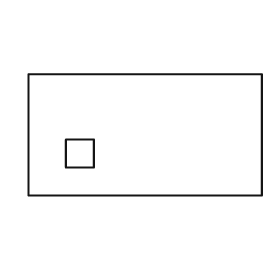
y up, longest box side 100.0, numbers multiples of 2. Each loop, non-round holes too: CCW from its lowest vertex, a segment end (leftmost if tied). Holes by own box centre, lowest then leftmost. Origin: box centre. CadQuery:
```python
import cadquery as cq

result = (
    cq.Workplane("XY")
    .moveTo(-50.0, -26.0)
    .lineTo(50.0, -26.0)
    .lineTo(50.0, 26.0)
    .lineTo(-50.0, 26.0)
    .close()
    .moveTo(-34.0, -14.0)
    .lineTo(-22.0, -14.0)
    .lineTo(-22.0, -2.0)
    .lineTo(-34.0, -2.0)
    .close()
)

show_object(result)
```